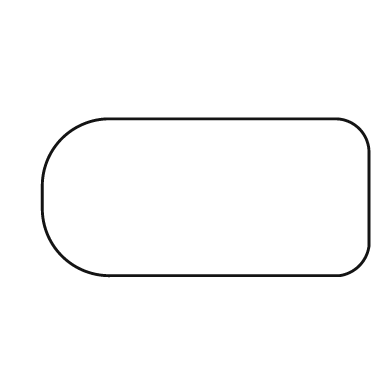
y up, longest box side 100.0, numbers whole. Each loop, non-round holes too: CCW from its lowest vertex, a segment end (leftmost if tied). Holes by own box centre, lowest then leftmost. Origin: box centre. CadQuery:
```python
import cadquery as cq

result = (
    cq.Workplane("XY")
    .moveTo(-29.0, -24.0)
    .lineTo(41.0, -24.0)
    .threePointArc((47.0, -21.0), (50.0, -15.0))
    .lineTo(50.0, 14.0)
    .threePointArc((47.0, 21.0), (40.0, 24.0))
    .lineTo(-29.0, 24.0)
    .threePointArc((-44.0, 18.0), (-50.0, 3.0))
    .lineTo(-50.0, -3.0)
    .threePointArc((-44.0, -18.0), (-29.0, -24.0))
    .close()
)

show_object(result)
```